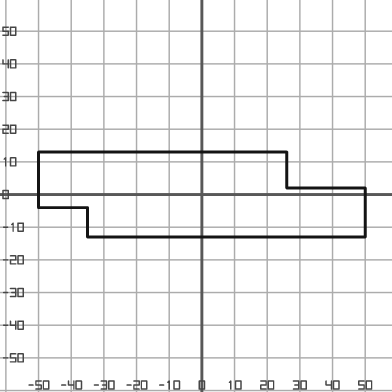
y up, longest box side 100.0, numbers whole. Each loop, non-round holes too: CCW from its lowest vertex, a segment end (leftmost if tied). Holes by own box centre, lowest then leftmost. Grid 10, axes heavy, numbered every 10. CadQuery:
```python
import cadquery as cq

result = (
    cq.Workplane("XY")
    .moveTo(-35.0, -13.0)
    .lineTo(50.0, -13.0)
    .lineTo(50.0, 2.0)
    .lineTo(26.0, 2.0)
    .lineTo(26.0, 13.0)
    .lineTo(-50.0, 13.0)
    .lineTo(-50.0, -4.0)
    .lineTo(-35.0, -4.0)
    .close()
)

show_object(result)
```